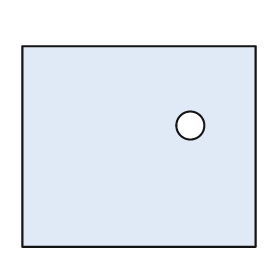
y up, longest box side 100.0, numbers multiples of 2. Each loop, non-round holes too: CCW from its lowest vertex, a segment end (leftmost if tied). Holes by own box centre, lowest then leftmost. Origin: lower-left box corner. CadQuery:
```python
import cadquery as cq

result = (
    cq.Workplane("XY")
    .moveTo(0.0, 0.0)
    .lineTo(100.0, 0.0)
    .lineTo(100.0, 86.0)
    .lineTo(0.0, 86.0)
    .close()
    .moveTo(72.0, 52.0)
    .circle(6.0)
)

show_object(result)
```